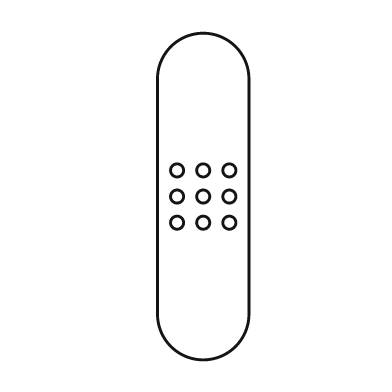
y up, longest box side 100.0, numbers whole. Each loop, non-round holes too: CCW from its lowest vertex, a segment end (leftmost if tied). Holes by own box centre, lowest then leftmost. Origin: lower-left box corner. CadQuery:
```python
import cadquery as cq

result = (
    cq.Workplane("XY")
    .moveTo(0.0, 14.0)
    .threePointArc((14.0, 0.0), (28.0, 14.0))
    .lineTo(28.0, 86.0)
    .threePointArc((14.0, 100.0), (0.0, 86.0))
    .close()
    .moveTo(6.0, 42.0)
    .circle(2.0)
    .moveTo(14.0, 42.0)
    .circle(2.0)
    .moveTo(22.0, 42.0)
    .circle(2.0)
    .moveTo(6.0, 50.0)
    .circle(2.0)
    .moveTo(14.0, 50.0)
    .circle(2.0)
    .moveTo(22.0, 50.0)
    .circle(2.0)
    .moveTo(6.0, 58.0)
    .circle(2.0)
    .moveTo(14.0, 58.0)
    .circle(2.0)
    .moveTo(22.0, 58.0)
    .circle(2.0)
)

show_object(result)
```